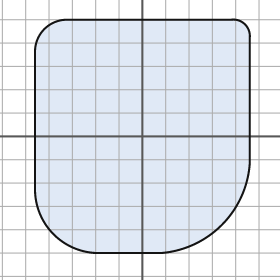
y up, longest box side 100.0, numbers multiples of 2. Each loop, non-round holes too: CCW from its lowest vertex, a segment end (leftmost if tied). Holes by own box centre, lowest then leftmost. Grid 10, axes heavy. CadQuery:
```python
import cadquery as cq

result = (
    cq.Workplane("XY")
    .moveTo(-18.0, -50.0)
    .lineTo(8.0, -50.0)
    .threePointArc((34.0, -38.0), (46.0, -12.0))
    .lineTo(46.0, 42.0)
    .threePointArc((44.0, 48.0), (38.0, 50.0))
    .lineTo(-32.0, 50.0)
    .threePointArc((-42.0, 46.0), (-46.0, 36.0))
    .lineTo(-46.0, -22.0)
    .threePointArc((-38.0, -42.0), (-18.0, -50.0))
    .close()
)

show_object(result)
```